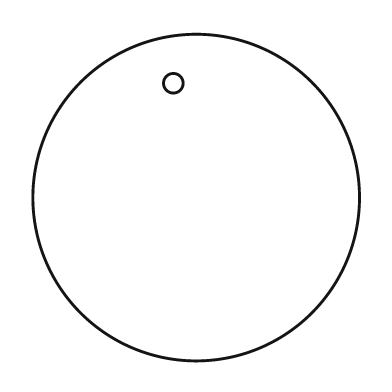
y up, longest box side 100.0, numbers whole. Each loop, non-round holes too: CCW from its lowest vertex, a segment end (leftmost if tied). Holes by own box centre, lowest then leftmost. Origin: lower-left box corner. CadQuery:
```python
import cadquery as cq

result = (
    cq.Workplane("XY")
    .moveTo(50.0, 50.0)
    .circle(50.0)
    .moveTo(43.0, 85.0)
    .circle(3.0)
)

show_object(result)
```